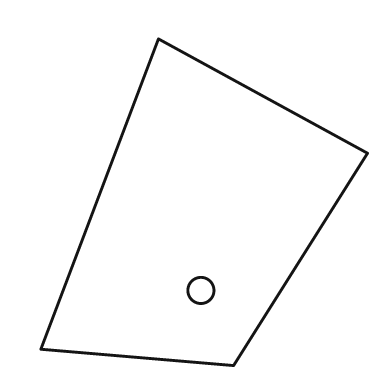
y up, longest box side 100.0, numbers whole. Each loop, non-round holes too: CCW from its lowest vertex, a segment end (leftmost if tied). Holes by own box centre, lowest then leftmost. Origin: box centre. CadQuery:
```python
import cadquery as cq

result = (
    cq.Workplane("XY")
    .moveTo(9.0, -50.0)
    .lineTo(50.0, 15.0)
    .lineTo(-14.0, 50.0)
    .lineTo(-50.0, -45.0)
    .close()
    .moveTo(-1.0, -27.0)
    .circle(4.0)
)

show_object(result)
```